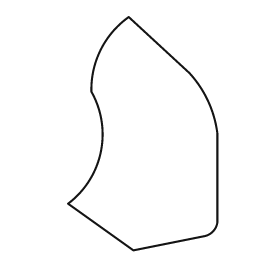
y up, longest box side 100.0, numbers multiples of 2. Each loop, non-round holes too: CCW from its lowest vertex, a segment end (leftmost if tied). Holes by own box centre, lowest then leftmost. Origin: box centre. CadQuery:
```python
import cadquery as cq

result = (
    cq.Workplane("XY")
    .moveTo(-4.0, -50.0)
    .lineTo(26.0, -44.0)
    .threePointArc((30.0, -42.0), (32.0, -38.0))
    .lineTo(32.0, 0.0)
    .threePointArc((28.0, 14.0), (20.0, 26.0))
    .lineTo(-6.0, 50.0)
    .threePointArc((-18.0, 36.0), (-22.0, 18.0))
    .threePointArc((-18.0, -8.0), (-32.0, -30.0))
    .close()
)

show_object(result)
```